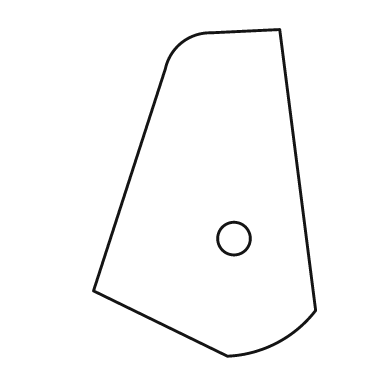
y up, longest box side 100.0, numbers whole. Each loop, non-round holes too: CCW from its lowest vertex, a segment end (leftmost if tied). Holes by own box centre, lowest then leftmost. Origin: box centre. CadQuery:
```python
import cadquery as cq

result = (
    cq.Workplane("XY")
    .moveTo(7.0, -50.0)
    .threePointArc((22.0, -46.0), (34.0, -36.0))
    .lineTo(23.0, 50.0)
    .lineTo(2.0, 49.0)
    .threePointArc((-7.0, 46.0), (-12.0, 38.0))
    .lineTo(-34.0, -30.0)
    .close()
    .moveTo(9.0, -14.0)
    .circle(5.0)
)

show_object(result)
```